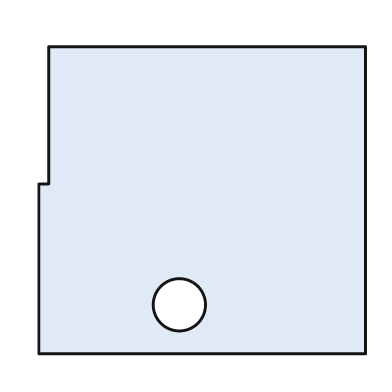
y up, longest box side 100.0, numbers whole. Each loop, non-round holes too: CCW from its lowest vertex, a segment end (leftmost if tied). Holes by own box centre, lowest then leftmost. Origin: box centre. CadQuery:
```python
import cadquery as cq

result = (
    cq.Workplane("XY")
    .moveTo(-50.0, -47.0)
    .lineTo(50.0, -47.0)
    .lineTo(50.0, 47.0)
    .lineTo(-47.0, 47.0)
    .lineTo(-47.0, 5.0)
    .lineTo(-50.0, 5.0)
    .close()
    .moveTo(-7.0, -32.0)
    .circle(8.0)
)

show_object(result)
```